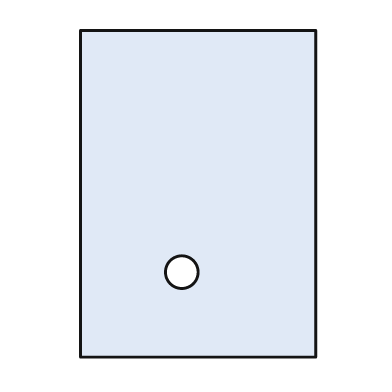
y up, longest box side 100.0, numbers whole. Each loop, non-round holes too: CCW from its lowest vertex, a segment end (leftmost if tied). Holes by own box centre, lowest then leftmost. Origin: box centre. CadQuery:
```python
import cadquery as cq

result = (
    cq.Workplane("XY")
    .moveTo(-36.0, -50.0)
    .lineTo(36.0, -50.0)
    .lineTo(36.0, 50.0)
    .lineTo(-36.0, 50.0)
    .close()
    .moveTo(-5.0, -24.0)
    .circle(5.0)
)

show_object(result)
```